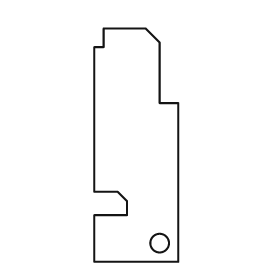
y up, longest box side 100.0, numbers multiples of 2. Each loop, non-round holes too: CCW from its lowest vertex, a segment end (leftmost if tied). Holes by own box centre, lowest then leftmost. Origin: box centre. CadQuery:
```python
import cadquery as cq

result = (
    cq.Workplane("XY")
    .moveTo(-18.0, -50.0)
    .lineTo(18.0, -50.0)
    .lineTo(18.0, 18.0)
    .lineTo(10.0, 18.0)
    .lineTo(10.0, 44.0)
    .lineTo(4.0, 50.0)
    .lineTo(-14.0, 50.0)
    .lineTo(-14.0, 42.0)
    .lineTo(-18.0, 42.0)
    .lineTo(-18.0, -20.0)
    .lineTo(-8.0, -20.0)
    .lineTo(-4.0, -24.0)
    .lineTo(-4.0, -30.0)
    .lineTo(-18.0, -30.0)
    .close()
    .moveTo(10.0, -42.0)
    .circle(4.0)
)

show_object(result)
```